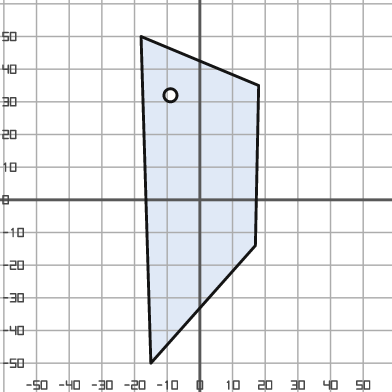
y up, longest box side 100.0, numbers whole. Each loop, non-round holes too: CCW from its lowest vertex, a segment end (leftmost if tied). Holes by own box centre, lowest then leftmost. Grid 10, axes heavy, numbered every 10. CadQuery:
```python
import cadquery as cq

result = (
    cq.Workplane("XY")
    .moveTo(-15.0, -50.0)
    .lineTo(17.0, -14.0)
    .lineTo(18.0, 35.0)
    .lineTo(-18.0, 50.0)
    .close()
    .moveTo(-9.0, 32.0)
    .circle(2.0)
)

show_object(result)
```